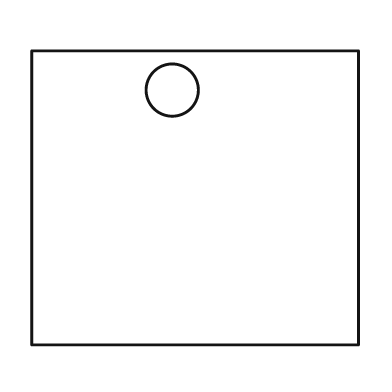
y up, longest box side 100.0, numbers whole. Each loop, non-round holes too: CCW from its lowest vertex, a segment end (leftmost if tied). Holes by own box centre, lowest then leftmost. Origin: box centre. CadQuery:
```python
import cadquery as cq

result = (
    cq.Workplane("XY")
    .moveTo(-50.0, -45.0)
    .lineTo(50.0, -45.0)
    .lineTo(50.0, 45.0)
    .lineTo(-50.0, 45.0)
    .close()
    .moveTo(-7.0, 33.0)
    .circle(8.0)
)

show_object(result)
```